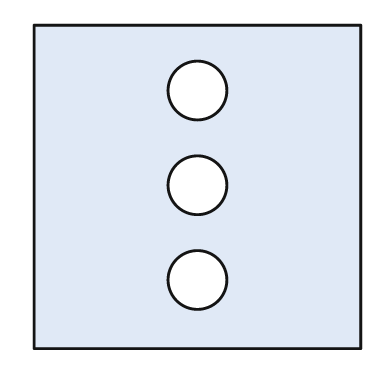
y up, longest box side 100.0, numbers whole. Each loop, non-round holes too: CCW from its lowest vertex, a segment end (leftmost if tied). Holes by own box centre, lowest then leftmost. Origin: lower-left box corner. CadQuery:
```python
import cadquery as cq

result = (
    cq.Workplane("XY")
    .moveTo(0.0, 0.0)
    .lineTo(100.0, 0.0)
    .lineTo(100.0, 99.0)
    .lineTo(0.0, 99.0)
    .close()
    .moveTo(50.0, 21.0)
    .circle(9.0)
    .moveTo(50.0, 50.0)
    .circle(9.0)
    .moveTo(50.0, 79.0)
    .circle(9.0)
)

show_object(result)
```